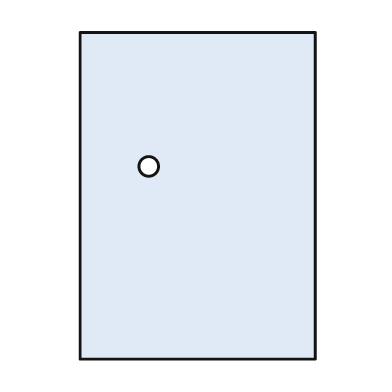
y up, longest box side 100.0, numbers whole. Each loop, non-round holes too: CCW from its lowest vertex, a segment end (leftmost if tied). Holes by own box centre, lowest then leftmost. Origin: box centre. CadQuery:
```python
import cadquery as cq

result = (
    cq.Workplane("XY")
    .moveTo(-36.0, -50.0)
    .lineTo(36.0, -50.0)
    .lineTo(36.0, 50.0)
    .lineTo(-36.0, 50.0)
    .close()
    .moveTo(-15.0, 9.0)
    .circle(3.0)
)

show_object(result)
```